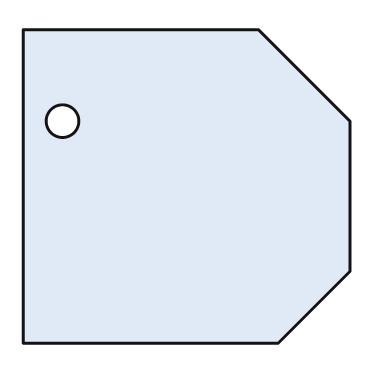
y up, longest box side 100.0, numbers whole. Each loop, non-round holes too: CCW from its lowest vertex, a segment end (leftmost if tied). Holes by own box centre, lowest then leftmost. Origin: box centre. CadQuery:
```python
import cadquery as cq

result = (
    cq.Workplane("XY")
    .moveTo(-50.0, -48.0)
    .lineTo(28.0, -48.0)
    .lineTo(50.0, -26.0)
    .lineTo(50.0, 20.0)
    .lineTo(22.0, 48.0)
    .lineTo(-50.0, 48.0)
    .close()
    .moveTo(-38.0, 20.0)
    .circle(5.0)
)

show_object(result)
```